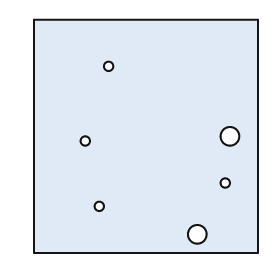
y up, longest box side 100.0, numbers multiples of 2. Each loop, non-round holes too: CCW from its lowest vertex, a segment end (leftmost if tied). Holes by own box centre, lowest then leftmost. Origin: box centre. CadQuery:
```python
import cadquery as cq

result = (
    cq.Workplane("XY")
    .moveTo(-48.0, -50.0)
    .lineTo(48.0, -50.0)
    .lineTo(48.0, 50.0)
    .lineTo(-48.0, 50.0)
    .close()
    .moveTo(22.0, -42.0)
    .circle(4.0)
    .moveTo(-20.0, -30.0)
    .circle(2.0)
    .moveTo(34.0, -20.0)
    .circle(2.0)
    .moveTo(-26.0, -2.0)
    .circle(2.0)
    .moveTo(36.0, 0.0)
    .circle(4.0)
    .moveTo(-16.0, 30.0)
    .circle(2.0)
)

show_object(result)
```